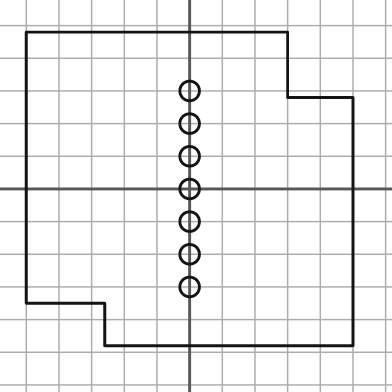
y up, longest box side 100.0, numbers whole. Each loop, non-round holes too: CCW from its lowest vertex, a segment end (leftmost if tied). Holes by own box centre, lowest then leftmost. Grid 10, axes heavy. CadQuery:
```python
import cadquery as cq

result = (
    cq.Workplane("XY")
    .moveTo(-26.0, -48.0)
    .lineTo(50.0, -48.0)
    .lineTo(50.0, 28.0)
    .lineTo(30.0, 28.0)
    .lineTo(30.0, 48.0)
    .lineTo(-50.0, 48.0)
    .lineTo(-50.0, -35.0)
    .lineTo(-26.0, -35.0)
    .close()
    .moveTo(0.0, -30.0)
    .circle(3.0)
    .moveTo(0.0, -20.0)
    .circle(3.0)
    .moveTo(0.0, -10.0)
    .circle(3.0)
    .moveTo(0.0, 0.0)
    .circle(3.0)
    .moveTo(0.0, 10.0)
    .circle(3.0)
    .moveTo(0.0, 20.0)
    .circle(3.0)
    .moveTo(0.0, 30.0)
    .circle(3.0)
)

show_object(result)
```